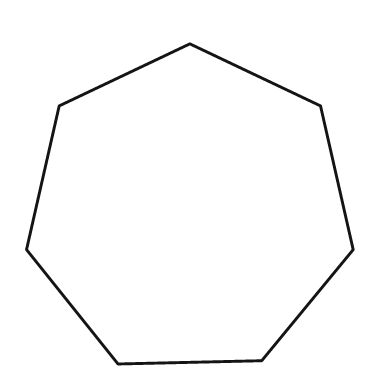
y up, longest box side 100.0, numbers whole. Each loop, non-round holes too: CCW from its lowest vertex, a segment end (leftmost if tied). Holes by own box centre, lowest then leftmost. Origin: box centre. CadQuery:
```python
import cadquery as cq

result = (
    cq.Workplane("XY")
    .moveTo(-22.0, -49.0)
    .lineTo(22.0, -48.0)
    .lineTo(50.0, -14.0)
    .lineTo(40.0, 30.0)
    .lineTo(0.0, 49.0)
    .lineTo(-40.0, 30.0)
    .lineTo(-50.0, -14.0)
    .close()
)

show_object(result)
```